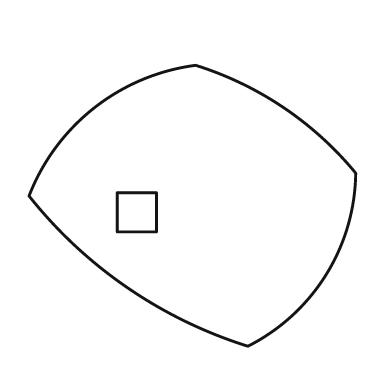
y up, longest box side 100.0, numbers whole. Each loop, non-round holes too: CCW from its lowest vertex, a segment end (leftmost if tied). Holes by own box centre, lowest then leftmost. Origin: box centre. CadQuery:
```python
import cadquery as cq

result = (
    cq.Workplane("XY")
    .moveTo(17.0, -43.0)
    .threePointArc((41.0, -21.0), (50.0, 10.0))
    .threePointArc((28.0, 30.0), (1.0, 43.0))
    .threePointArc((-30.0, 30.0), (-50.0, 3.0))
    .threePointArc((-20.0, -25.0), (17.0, -43.0))
    .close()
    .moveTo(-23.0, -8.0)
    .lineTo(-11.0, -8.0)
    .lineTo(-11.0, 4.0)
    .lineTo(-23.0, 4.0)
    .close()
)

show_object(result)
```